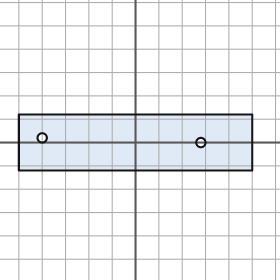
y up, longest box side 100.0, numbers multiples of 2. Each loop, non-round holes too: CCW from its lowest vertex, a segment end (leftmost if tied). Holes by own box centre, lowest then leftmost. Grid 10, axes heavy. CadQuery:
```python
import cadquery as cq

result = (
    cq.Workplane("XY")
    .moveTo(-50.0, -12.0)
    .lineTo(50.0, -12.0)
    .lineTo(50.0, 12.0)
    .lineTo(-50.0, 12.0)
    .close()
    .moveTo(28.0, 0.0)
    .circle(2.0)
    .moveTo(-40.0, 2.0)
    .circle(2.0)
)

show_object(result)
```